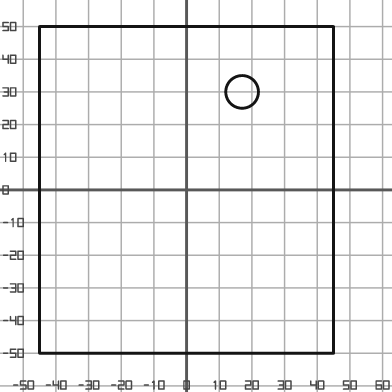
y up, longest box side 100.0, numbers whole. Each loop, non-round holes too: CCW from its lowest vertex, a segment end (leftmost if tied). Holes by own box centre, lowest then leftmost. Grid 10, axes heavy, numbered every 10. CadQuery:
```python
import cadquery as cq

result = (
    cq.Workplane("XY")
    .moveTo(-45.0, -50.0)
    .lineTo(45.0, -50.0)
    .lineTo(45.0, 50.0)
    .lineTo(-45.0, 50.0)
    .close()
    .moveTo(17.0, 30.0)
    .circle(5.0)
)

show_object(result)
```